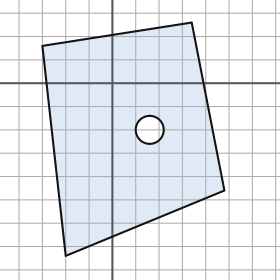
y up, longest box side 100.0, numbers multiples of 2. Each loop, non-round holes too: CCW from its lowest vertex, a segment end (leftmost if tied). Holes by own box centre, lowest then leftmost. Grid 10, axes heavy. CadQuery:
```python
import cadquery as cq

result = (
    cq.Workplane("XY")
    .moveTo(-20.0, -74.0)
    .lineTo(48.0, -46.0)
    .lineTo(34.0, 26.0)
    .lineTo(-30.0, 16.0)
    .close()
    .moveTo(16.0, -20.0)
    .circle(6.0)
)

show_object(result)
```